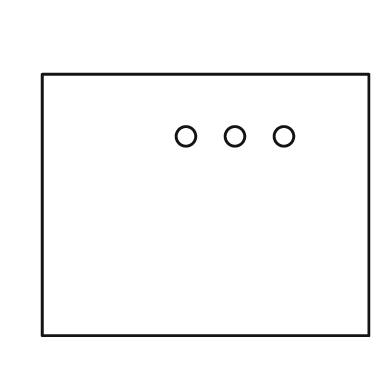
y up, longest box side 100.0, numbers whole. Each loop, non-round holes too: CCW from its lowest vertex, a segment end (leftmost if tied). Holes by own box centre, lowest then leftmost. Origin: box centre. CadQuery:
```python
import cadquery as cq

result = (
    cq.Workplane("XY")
    .moveTo(-50.0, -40.0)
    .lineTo(50.0, -40.0)
    .lineTo(50.0, 40.0)
    .lineTo(-50.0, 40.0)
    .close()
    .moveTo(-6.0, 21.0)
    .circle(3.0)
    .moveTo(9.0, 21.0)
    .circle(3.0)
    .moveTo(24.0, 21.0)
    .circle(3.0)
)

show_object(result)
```